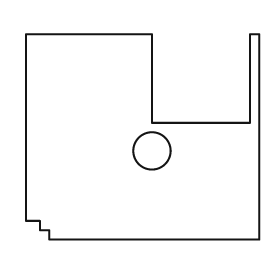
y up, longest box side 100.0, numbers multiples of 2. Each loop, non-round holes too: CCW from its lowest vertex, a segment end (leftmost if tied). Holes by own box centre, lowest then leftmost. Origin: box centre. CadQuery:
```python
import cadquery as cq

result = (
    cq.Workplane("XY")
    .moveTo(-40.0, -44.0)
    .lineTo(50.0, -44.0)
    .lineTo(50.0, 44.0)
    .lineTo(46.0, 44.0)
    .lineTo(46.0, 6.0)
    .lineTo(4.0, 6.0)
    .lineTo(4.0, 44.0)
    .lineTo(-50.0, 44.0)
    .lineTo(-50.0, -36.0)
    .lineTo(-44.0, -36.0)
    .lineTo(-44.0, -40.0)
    .lineTo(-40.0, -40.0)
    .close()
    .moveTo(4.0, -6.0)
    .circle(8.0)
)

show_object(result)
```